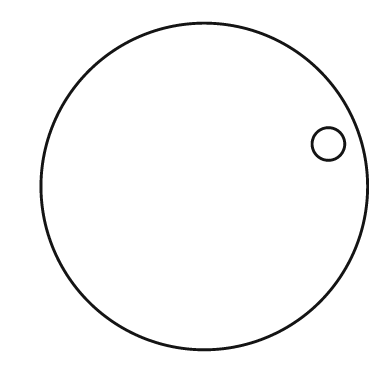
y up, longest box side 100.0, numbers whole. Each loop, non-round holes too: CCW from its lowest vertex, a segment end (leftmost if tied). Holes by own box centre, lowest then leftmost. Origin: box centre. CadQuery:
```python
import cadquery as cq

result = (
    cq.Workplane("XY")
    .moveTo(0.0, 0.0)
    .circle(50.0)
    .moveTo(38.0, 13.0)
    .circle(5.0)
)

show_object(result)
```